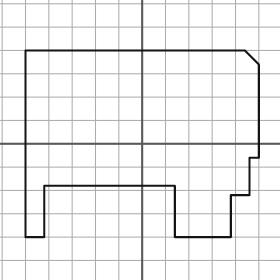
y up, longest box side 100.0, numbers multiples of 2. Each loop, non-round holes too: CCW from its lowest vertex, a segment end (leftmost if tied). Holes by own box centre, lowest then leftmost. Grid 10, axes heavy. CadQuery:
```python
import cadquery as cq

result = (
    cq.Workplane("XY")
    .moveTo(-50.0, -40.0)
    .lineTo(-42.0, -40.0)
    .lineTo(-42.0, -18.0)
    .lineTo(14.0, -18.0)
    .lineTo(14.0, -40.0)
    .lineTo(38.0, -40.0)
    .lineTo(38.0, -22.0)
    .lineTo(46.0, -22.0)
    .lineTo(46.0, -6.0)
    .lineTo(50.0, -6.0)
    .lineTo(50.0, 34.0)
    .lineTo(44.0, 40.0)
    .lineTo(-50.0, 40.0)
    .close()
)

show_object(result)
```